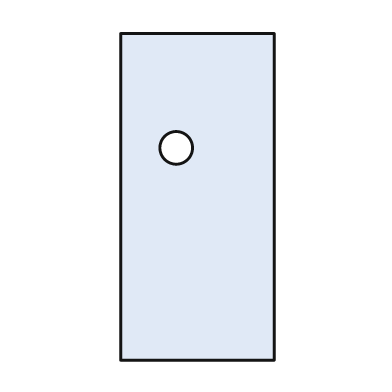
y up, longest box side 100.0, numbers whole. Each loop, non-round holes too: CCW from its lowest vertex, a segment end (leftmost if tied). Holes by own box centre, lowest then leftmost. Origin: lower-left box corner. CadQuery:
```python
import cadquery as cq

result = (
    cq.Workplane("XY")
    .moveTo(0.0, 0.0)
    .lineTo(47.0, 0.0)
    .lineTo(47.0, 100.0)
    .lineTo(0.0, 100.0)
    .close()
    .moveTo(17.0, 65.0)
    .circle(5.0)
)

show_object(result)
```